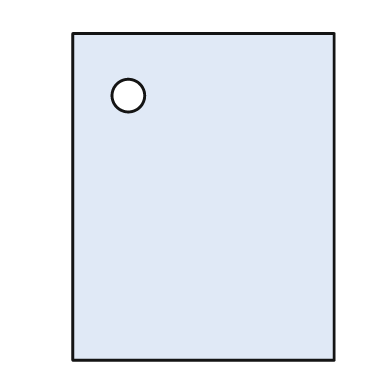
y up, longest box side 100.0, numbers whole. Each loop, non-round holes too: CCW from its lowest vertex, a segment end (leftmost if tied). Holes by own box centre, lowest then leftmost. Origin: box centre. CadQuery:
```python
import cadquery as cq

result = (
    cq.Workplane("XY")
    .moveTo(-40.0, -50.0)
    .lineTo(40.0, -50.0)
    .lineTo(40.0, 50.0)
    .lineTo(-40.0, 50.0)
    .close()
    .moveTo(-23.0, 31.0)
    .circle(5.0)
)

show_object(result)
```